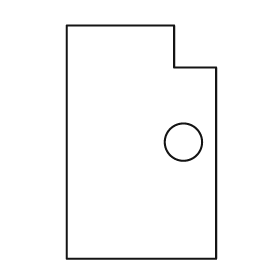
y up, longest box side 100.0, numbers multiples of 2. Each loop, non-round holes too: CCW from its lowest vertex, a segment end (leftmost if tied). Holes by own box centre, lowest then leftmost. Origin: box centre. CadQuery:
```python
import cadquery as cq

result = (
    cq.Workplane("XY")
    .moveTo(-32.0, -50.0)
    .lineTo(32.0, -50.0)
    .lineTo(32.0, 32.0)
    .lineTo(14.0, 32.0)
    .lineTo(14.0, 50.0)
    .lineTo(-32.0, 50.0)
    .close()
    .moveTo(18.0, 0.0)
    .circle(8.0)
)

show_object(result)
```